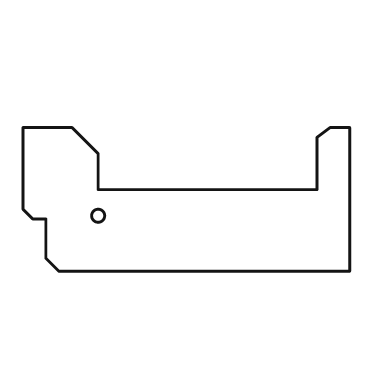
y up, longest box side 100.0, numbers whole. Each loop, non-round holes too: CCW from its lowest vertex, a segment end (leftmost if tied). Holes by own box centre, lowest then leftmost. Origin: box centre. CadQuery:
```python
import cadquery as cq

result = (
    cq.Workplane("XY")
    .moveTo(-39.0, -22.0)
    .lineTo(50.0, -22.0)
    .lineTo(50.0, 22.0)
    .lineTo(44.0, 22.0)
    .lineTo(40.0, 19.0)
    .lineTo(40.0, 3.0)
    .lineTo(-27.0, 3.0)
    .lineTo(-27.0, 14.0)
    .lineTo(-35.0, 22.0)
    .lineTo(-50.0, 22.0)
    .lineTo(-50.0, -3.0)
    .lineTo(-47.0, -6.0)
    .lineTo(-43.0, -6.0)
    .lineTo(-43.0, -18.0)
    .close()
    .moveTo(-27.0, -5.0)
    .circle(2.0)
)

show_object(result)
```